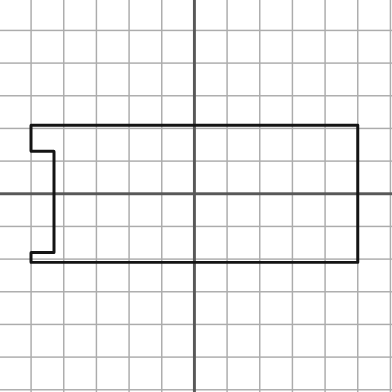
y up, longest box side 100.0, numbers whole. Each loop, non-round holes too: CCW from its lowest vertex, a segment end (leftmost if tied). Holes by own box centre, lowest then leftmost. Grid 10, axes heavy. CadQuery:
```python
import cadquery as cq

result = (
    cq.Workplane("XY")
    .moveTo(-50.0, -21.0)
    .lineTo(50.0, -21.0)
    .lineTo(50.0, 21.0)
    .lineTo(-50.0, 21.0)
    .lineTo(-50.0, 13.0)
    .lineTo(-43.0, 13.0)
    .lineTo(-43.0, -18.0)
    .lineTo(-50.0, -18.0)
    .close()
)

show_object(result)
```